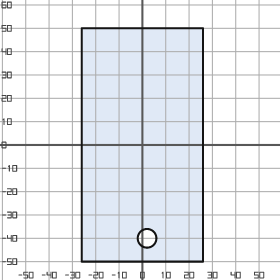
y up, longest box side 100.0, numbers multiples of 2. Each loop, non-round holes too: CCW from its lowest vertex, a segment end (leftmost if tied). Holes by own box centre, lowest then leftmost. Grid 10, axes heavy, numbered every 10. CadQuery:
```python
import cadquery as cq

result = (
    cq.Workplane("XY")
    .moveTo(-26.0, -50.0)
    .lineTo(26.0, -50.0)
    .lineTo(26.0, 50.0)
    .lineTo(-26.0, 50.0)
    .close()
    .moveTo(2.0, -40.0)
    .circle(4.0)
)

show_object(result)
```